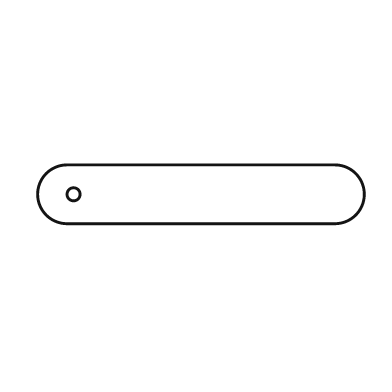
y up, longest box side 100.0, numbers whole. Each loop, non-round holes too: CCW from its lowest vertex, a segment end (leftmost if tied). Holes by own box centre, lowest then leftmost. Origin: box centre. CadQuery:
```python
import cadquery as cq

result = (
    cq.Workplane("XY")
    .moveTo(-41.0, -9.0)
    .lineTo(41.0, -9.0)
    .threePointArc((50.0, 0.0), (41.0, 9.0))
    .lineTo(-41.0, 9.0)
    .threePointArc((-50.0, 0.0), (-41.0, -9.0))
    .close()
    .moveTo(-39.0, 0.0)
    .circle(2.0)
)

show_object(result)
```